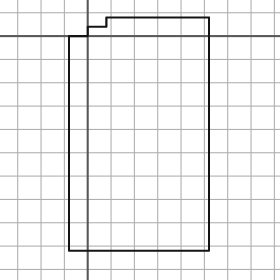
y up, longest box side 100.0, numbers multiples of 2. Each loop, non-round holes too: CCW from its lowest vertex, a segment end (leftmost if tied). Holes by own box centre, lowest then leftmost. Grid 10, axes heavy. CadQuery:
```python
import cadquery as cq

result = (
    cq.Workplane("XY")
    .moveTo(-8.0, -92.0)
    .lineTo(52.0, -92.0)
    .lineTo(52.0, 8.0)
    .lineTo(8.0, 8.0)
    .lineTo(8.0, 4.0)
    .lineTo(0.0, 4.0)
    .lineTo(0.0, 0.0)
    .lineTo(-8.0, 0.0)
    .close()
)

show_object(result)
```